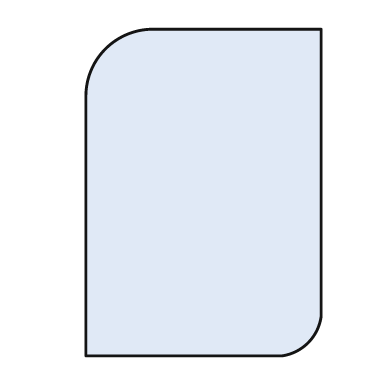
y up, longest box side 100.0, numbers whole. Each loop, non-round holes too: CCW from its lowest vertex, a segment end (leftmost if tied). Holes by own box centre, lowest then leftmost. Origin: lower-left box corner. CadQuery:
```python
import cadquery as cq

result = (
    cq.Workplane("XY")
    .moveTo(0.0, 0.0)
    .lineTo(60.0, 0.0)
    .threePointArc((68.0, 4.0), (72.0, 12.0))
    .lineTo(72.0, 100.0)
    .lineTo(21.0, 100.0)
    .threePointArc((6.0, 94.0), (0.0, 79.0))
    .close()
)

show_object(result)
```